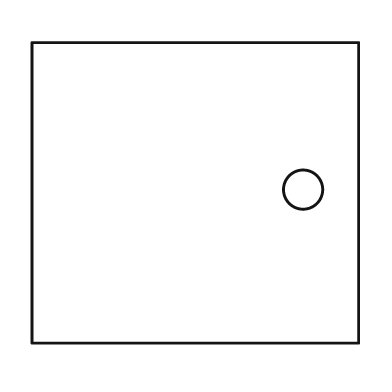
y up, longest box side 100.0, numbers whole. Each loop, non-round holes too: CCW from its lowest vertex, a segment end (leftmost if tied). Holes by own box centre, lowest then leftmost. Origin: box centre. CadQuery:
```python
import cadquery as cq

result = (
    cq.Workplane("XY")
    .moveTo(-50.0, -46.0)
    .lineTo(50.0, -46.0)
    .lineTo(50.0, 46.0)
    .lineTo(-50.0, 46.0)
    .close()
    .moveTo(33.0, 1.0)
    .circle(6.0)
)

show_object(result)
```